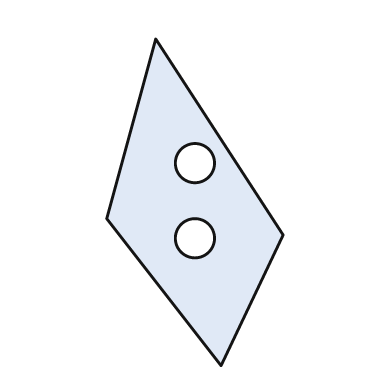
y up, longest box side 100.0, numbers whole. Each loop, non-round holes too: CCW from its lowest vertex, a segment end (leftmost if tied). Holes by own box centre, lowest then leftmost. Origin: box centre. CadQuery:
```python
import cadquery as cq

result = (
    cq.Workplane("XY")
    .moveTo(8.0, -50.0)
    .lineTo(27.0, -10.0)
    .lineTo(-12.0, 50.0)
    .lineTo(-27.0, -5.0)
    .close()
    .moveTo(0.0, -11.0)
    .circle(6.0)
    .moveTo(0.0, 12.0)
    .circle(6.0)
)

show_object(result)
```